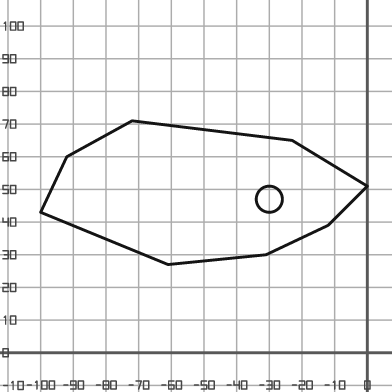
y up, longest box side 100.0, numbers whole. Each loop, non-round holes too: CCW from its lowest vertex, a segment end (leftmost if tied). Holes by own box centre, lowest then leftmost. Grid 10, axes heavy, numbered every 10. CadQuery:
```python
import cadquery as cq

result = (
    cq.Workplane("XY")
    .moveTo(-61.0, 27.0)
    .lineTo(-31.0, 30.0)
    .lineTo(-12.0, 39.0)
    .lineTo(0.0, 51.0)
    .lineTo(-23.0, 65.0)
    .lineTo(-72.0, 71.0)
    .lineTo(-92.0, 60.0)
    .lineTo(-100.0, 43.0)
    .close()
    .moveTo(-30.0, 47.0)
    .circle(4.0)
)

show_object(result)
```